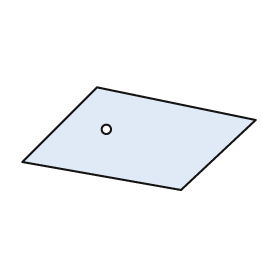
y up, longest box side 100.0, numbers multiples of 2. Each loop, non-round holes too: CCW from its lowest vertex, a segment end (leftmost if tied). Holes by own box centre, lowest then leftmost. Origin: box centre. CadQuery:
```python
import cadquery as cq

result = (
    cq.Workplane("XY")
    .moveTo(18.0, -22.0)
    .lineTo(50.0, 8.0)
    .lineTo(-18.0, 22.0)
    .lineTo(-50.0, -10.0)
    .close()
    .moveTo(-14.0, 4.0)
    .circle(2.0)
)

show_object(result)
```